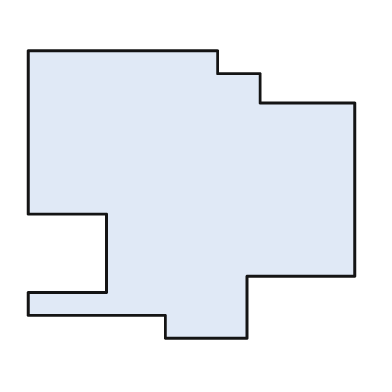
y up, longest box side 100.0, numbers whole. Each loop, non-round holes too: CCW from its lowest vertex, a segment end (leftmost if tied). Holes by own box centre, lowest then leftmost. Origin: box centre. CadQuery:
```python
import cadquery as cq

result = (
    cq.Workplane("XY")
    .moveTo(-8.0, -44.0)
    .lineTo(17.0, -44.0)
    .lineTo(17.0, -25.0)
    .lineTo(50.0, -25.0)
    .lineTo(50.0, 28.0)
    .lineTo(21.0, 28.0)
    .lineTo(21.0, 37.0)
    .lineTo(8.0, 37.0)
    .lineTo(8.0, 44.0)
    .lineTo(-50.0, 44.0)
    .lineTo(-50.0, -6.0)
    .lineTo(-26.0, -6.0)
    .lineTo(-26.0, -30.0)
    .lineTo(-50.0, -30.0)
    .lineTo(-50.0, -37.0)
    .lineTo(-8.0, -37.0)
    .close()
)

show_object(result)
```